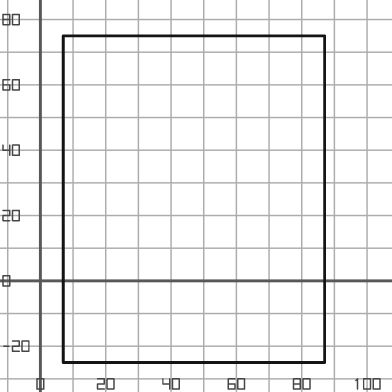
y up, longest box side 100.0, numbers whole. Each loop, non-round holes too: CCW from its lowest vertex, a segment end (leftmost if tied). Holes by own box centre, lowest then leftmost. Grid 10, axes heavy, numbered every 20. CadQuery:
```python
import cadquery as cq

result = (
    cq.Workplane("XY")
    .moveTo(7.0, -25.0)
    .lineTo(87.0, -25.0)
    .lineTo(87.0, 75.0)
    .lineTo(7.0, 75.0)
    .close()
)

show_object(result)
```